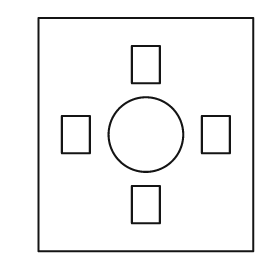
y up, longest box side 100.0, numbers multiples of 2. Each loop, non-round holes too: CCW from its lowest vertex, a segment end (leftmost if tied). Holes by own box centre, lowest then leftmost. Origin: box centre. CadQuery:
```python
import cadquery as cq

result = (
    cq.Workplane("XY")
    .moveTo(-46.0, -50.0)
    .lineTo(46.0, -50.0)
    .lineTo(46.0, 50.0)
    .lineTo(-46.0, 50.0)
    .close()
    .moveTo(-6.0, -38.0)
    .lineTo(6.0, -38.0)
    .lineTo(6.0, -22.0)
    .lineTo(-6.0, -22.0)
    .close()
    .moveTo(-36.0, -8.0)
    .lineTo(-24.0, -8.0)
    .lineTo(-24.0, 8.0)
    .lineTo(-36.0, 8.0)
    .close()
    .moveTo(0.0, 0.0)
    .circle(16.0)
    .moveTo(24.0, -8.0)
    .lineTo(36.0, -8.0)
    .lineTo(36.0, 8.0)
    .lineTo(24.0, 8.0)
    .close()
    .moveTo(-6.0, 22.0)
    .lineTo(6.0, 22.0)
    .lineTo(6.0, 38.0)
    .lineTo(-6.0, 38.0)
    .close()
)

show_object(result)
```